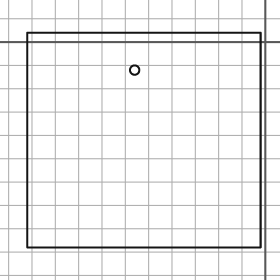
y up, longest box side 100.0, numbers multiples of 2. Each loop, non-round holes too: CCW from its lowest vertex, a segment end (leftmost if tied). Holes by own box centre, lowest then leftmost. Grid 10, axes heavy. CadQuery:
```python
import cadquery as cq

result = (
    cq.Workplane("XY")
    .moveTo(-102.0, -88.0)
    .lineTo(-2.0, -88.0)
    .lineTo(-2.0, 4.0)
    .lineTo(-102.0, 4.0)
    .close()
    .moveTo(-56.0, -12.0)
    .circle(2.0)
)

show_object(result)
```